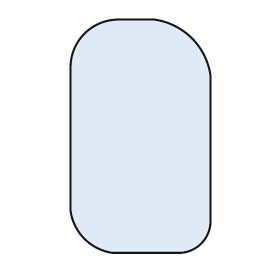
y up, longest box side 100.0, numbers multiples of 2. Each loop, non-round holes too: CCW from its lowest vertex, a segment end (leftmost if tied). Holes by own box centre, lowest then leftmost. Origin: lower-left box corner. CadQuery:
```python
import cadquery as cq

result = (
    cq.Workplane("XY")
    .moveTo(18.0, 0.0)
    .lineTo(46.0, 0.0)
    .threePointArc((56.0, 4.0), (60.0, 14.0))
    .lineTo(60.0, 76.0)
    .threePointArc((52.0, 92.0), (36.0, 100.0))
    .lineTo(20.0, 100.0)
    .threePointArc((6.0, 94.0), (0.0, 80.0))
    .lineTo(0.0, 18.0)
    .threePointArc((6.0, 6.0), (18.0, 0.0))
    .close()
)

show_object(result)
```